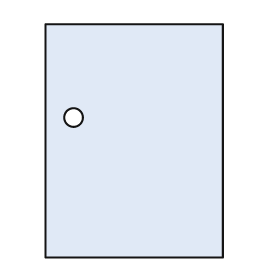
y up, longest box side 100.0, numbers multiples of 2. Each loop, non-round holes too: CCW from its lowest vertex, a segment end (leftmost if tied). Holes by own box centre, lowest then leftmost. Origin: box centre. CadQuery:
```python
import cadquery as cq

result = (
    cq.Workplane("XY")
    .moveTo(-38.0, -50.0)
    .lineTo(38.0, -50.0)
    .lineTo(38.0, 50.0)
    .lineTo(-38.0, 50.0)
    .close()
    .moveTo(-26.0, 10.0)
    .circle(4.0)
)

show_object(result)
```